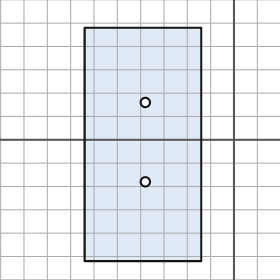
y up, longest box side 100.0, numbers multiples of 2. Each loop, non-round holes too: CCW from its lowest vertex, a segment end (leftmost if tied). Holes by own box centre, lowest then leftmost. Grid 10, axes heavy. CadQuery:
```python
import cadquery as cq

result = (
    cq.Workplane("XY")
    .moveTo(-64.0, -52.0)
    .lineTo(-14.0, -52.0)
    .lineTo(-14.0, 48.0)
    .lineTo(-64.0, 48.0)
    .close()
    .moveTo(-38.0, -18.0)
    .circle(2.0)
    .moveTo(-38.0, 16.0)
    .circle(2.0)
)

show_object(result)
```